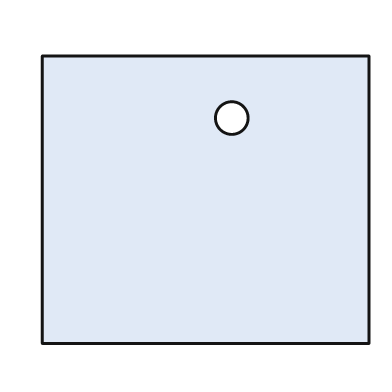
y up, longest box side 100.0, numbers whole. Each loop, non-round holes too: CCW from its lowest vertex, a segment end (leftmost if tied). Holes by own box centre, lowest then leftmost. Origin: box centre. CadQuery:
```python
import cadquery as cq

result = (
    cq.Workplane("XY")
    .moveTo(-50.0, -44.0)
    .lineTo(50.0, -44.0)
    .lineTo(50.0, 44.0)
    .lineTo(-50.0, 44.0)
    .close()
    .moveTo(8.0, 25.0)
    .circle(5.0)
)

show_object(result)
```